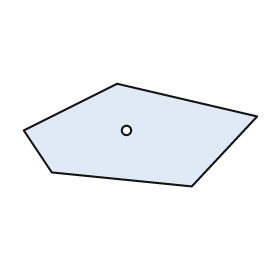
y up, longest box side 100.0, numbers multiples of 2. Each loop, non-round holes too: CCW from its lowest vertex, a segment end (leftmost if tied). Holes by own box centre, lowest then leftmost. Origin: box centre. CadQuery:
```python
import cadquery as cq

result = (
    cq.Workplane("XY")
    .moveTo(22.0, -22.0)
    .lineTo(50.0, 8.0)
    .lineTo(-10.0, 22.0)
    .lineTo(-50.0, 2.0)
    .lineTo(-38.0, -16.0)
    .close()
    .moveTo(-6.0, 2.0)
    .circle(2.0)
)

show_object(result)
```